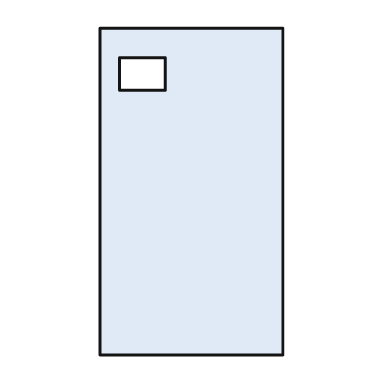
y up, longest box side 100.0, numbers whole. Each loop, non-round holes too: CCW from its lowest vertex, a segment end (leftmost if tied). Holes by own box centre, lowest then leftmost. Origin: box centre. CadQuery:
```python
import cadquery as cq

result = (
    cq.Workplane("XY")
    .moveTo(-28.0, -50.0)
    .lineTo(28.0, -50.0)
    .lineTo(28.0, 50.0)
    .lineTo(-28.0, 50.0)
    .close()
    .moveTo(-22.0, 31.0)
    .lineTo(-8.0, 31.0)
    .lineTo(-8.0, 41.0)
    .lineTo(-22.0, 41.0)
    .close()
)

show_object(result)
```